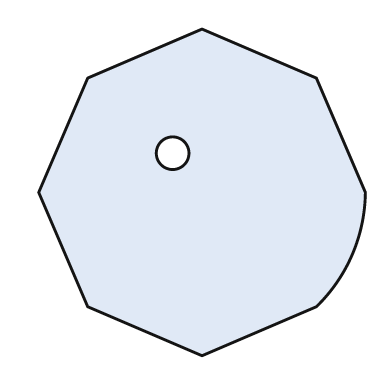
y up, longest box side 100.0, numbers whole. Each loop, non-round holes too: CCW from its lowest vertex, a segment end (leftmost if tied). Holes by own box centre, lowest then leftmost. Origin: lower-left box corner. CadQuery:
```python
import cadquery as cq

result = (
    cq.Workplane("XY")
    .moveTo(50.0, 0.0)
    .lineTo(85.0, 15.0)
    .threePointArc((96.0, 31.0), (100.0, 50.0))
    .lineTo(85.0, 85.0)
    .lineTo(50.0, 100.0)
    .lineTo(15.0, 85.0)
    .lineTo(0.0, 50.0)
    .lineTo(15.0, 15.0)
    .close()
    .moveTo(41.0, 62.0)
    .circle(5.0)
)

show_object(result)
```